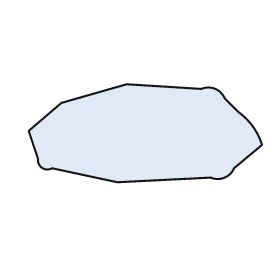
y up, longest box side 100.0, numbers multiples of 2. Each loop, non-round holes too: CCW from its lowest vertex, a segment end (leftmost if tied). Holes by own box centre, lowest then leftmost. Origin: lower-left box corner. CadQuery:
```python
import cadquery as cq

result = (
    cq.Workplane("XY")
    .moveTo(38.0, 0.0)
    .lineTo(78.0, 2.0)
    .threePointArc((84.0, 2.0), (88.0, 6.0))
    .lineTo(100.0, 16.0)
    .threePointArc((96.0, 24.0), (90.0, 30.0))
    .lineTo(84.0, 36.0)
    .threePointArc((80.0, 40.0), (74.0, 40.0))
    .lineTo(42.0, 42.0)
    .lineTo(14.0, 34.0)
    .lineTo(0.0, 22.0)
    .lineTo(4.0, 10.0)
    .threePointArc((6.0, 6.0), (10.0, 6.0))
    .close()
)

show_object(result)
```